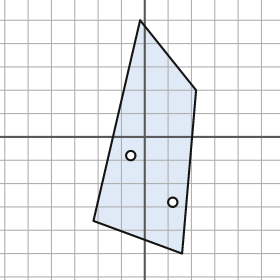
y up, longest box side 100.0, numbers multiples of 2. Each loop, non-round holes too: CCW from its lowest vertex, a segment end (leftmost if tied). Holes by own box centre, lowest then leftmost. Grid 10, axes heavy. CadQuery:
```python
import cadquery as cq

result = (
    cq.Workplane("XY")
    .moveTo(16.0, -50.0)
    .lineTo(22.0, 20.0)
    .lineTo(-2.0, 50.0)
    .lineTo(-22.0, -36.0)
    .close()
    .moveTo(12.0, -28.0)
    .circle(2.0)
    .moveTo(-6.0, -8.0)
    .circle(2.0)
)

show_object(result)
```